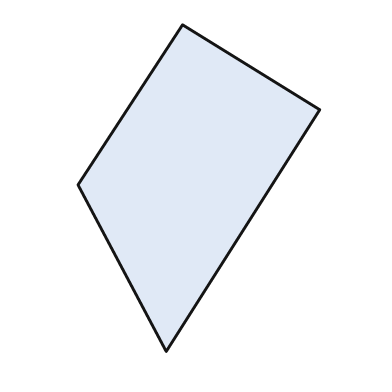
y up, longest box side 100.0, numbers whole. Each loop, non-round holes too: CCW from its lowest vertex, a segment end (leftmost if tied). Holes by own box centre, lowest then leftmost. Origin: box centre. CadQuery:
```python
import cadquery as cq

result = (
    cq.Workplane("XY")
    .moveTo(-10.0, -50.0)
    .lineTo(37.0, 24.0)
    .lineTo(-5.0, 50.0)
    .lineTo(-37.0, 1.0)
    .close()
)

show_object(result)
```